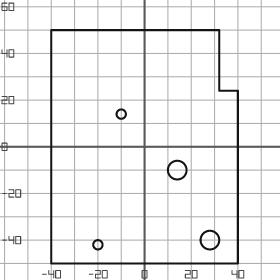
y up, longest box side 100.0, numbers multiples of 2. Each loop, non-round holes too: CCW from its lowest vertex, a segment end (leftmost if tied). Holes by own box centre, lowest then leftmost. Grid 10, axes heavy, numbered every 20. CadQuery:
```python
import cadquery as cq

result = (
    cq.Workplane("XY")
    .moveTo(-40.0, -50.0)
    .lineTo(40.0, -50.0)
    .lineTo(40.0, 24.0)
    .lineTo(32.0, 24.0)
    .lineTo(32.0, 50.0)
    .lineTo(-40.0, 50.0)
    .close()
    .moveTo(-20.0, -42.0)
    .circle(2.0)
    .moveTo(28.0, -40.0)
    .circle(4.0)
    .moveTo(14.0, -10.0)
    .circle(4.0)
    .moveTo(-10.0, 14.0)
    .circle(2.0)
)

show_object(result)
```